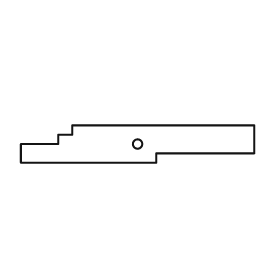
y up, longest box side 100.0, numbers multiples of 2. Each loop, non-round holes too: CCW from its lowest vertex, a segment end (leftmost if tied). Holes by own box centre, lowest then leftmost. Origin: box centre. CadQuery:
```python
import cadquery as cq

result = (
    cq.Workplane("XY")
    .moveTo(-50.0, -8.0)
    .lineTo(8.0, -8.0)
    .lineTo(8.0, -4.0)
    .lineTo(50.0, -4.0)
    .lineTo(50.0, 8.0)
    .lineTo(-28.0, 8.0)
    .lineTo(-28.0, 4.0)
    .lineTo(-34.0, 4.0)
    .lineTo(-34.0, 0.0)
    .lineTo(-50.0, 0.0)
    .close()
    .moveTo(0.0, 0.0)
    .circle(2.0)
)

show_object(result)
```